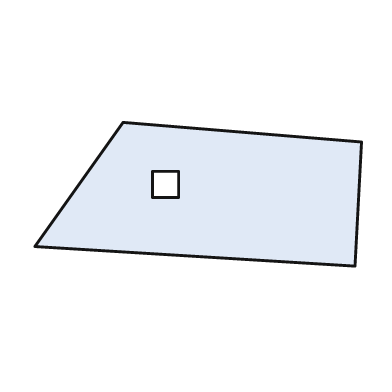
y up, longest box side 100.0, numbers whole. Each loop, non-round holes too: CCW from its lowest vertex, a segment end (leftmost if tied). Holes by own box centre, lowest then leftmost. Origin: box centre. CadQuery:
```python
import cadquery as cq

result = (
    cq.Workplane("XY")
    .moveTo(48.0, -22.0)
    .lineTo(50.0, 16.0)
    .lineTo(-23.0, 22.0)
    .lineTo(-50.0, -16.0)
    .close()
    .moveTo(-14.0, -1.0)
    .lineTo(-6.0, -1.0)
    .lineTo(-6.0, 7.0)
    .lineTo(-14.0, 7.0)
    .close()
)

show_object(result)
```